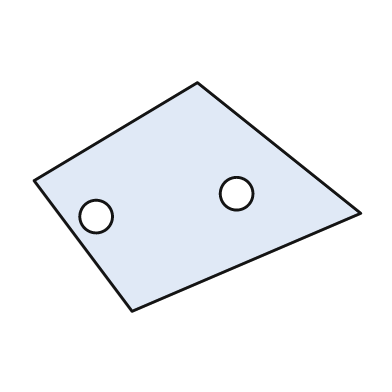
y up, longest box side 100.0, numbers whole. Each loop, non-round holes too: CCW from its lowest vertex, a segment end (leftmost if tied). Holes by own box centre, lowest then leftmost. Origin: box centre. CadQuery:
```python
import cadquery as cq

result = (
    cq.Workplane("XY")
    .moveTo(-20.0, -35.0)
    .lineTo(50.0, -5.0)
    .lineTo(0.0, 35.0)
    .lineTo(-50.0, 5.0)
    .close()
    .moveTo(-31.0, -6.0)
    .circle(5.0)
    .moveTo(12.0, 1.0)
    .circle(5.0)
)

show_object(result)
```